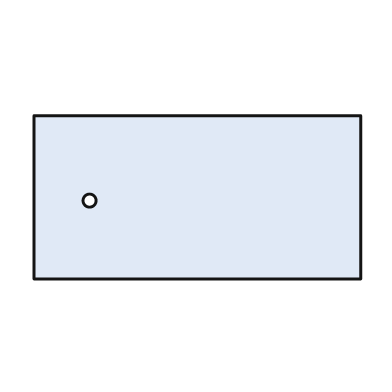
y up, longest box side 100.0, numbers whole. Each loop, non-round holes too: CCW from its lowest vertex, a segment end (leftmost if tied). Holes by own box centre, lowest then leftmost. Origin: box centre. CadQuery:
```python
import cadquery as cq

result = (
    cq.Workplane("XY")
    .moveTo(-50.0, -25.0)
    .lineTo(50.0, -25.0)
    .lineTo(50.0, 25.0)
    .lineTo(-50.0, 25.0)
    .close()
    .moveTo(-33.0, -1.0)
    .circle(2.0)
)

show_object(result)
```